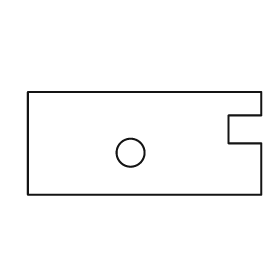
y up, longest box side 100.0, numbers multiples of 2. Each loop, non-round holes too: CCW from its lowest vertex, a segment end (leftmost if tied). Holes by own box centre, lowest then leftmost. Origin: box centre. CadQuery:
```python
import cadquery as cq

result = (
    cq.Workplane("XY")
    .moveTo(-50.0, -22.0)
    .lineTo(50.0, -22.0)
    .lineTo(50.0, 0.0)
    .lineTo(36.0, 0.0)
    .lineTo(36.0, 12.0)
    .lineTo(50.0, 12.0)
    .lineTo(50.0, 22.0)
    .lineTo(-50.0, 22.0)
    .close()
    .moveTo(-6.0, -4.0)
    .circle(6.0)
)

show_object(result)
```